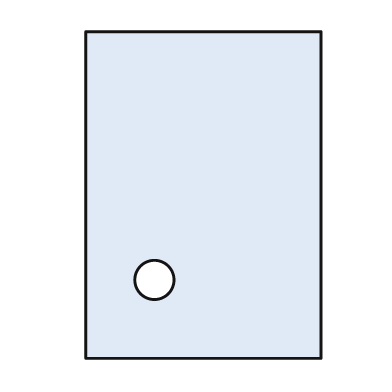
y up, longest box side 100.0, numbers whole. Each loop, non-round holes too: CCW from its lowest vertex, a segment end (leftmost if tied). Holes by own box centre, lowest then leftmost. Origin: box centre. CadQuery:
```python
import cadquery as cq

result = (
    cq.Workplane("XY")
    .moveTo(-36.0, -50.0)
    .lineTo(36.0, -50.0)
    .lineTo(36.0, 50.0)
    .lineTo(-36.0, 50.0)
    .close()
    .moveTo(-15.0, -26.0)
    .circle(6.0)
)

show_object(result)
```